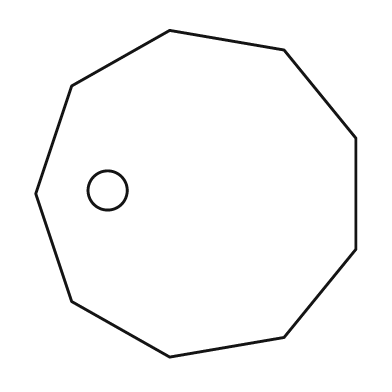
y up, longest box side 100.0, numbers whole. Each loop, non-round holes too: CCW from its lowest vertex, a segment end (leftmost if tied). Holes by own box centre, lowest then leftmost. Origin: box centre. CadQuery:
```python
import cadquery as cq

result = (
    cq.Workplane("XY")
    .moveTo(-8.0, -50.0)
    .lineTo(27.0, -44.0)
    .lineTo(49.0, -17.0)
    .lineTo(49.0, 17.0)
    .lineTo(27.0, 44.0)
    .lineTo(-8.0, 50.0)
    .lineTo(-38.0, 33.0)
    .lineTo(-49.0, 0.0)
    .lineTo(-38.0, -33.0)
    .close()
    .moveTo(-27.0, 1.0)
    .circle(6.0)
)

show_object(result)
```